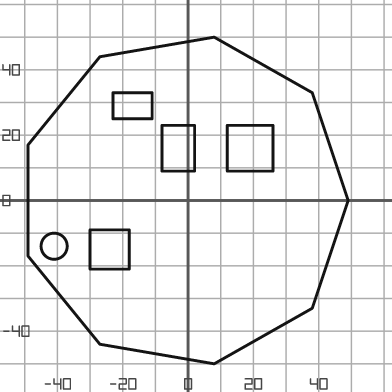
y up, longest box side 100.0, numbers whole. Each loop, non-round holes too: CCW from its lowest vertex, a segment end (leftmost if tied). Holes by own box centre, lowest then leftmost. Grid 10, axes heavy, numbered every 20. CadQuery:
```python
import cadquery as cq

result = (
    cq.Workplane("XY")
    .moveTo(8.0, -50.0)
    .lineTo(38.0, -33.0)
    .lineTo(49.0, 0.0)
    .lineTo(38.0, 33.0)
    .lineTo(8.0, 50.0)
    .lineTo(-27.0, 44.0)
    .lineTo(-49.0, 17.0)
    .lineTo(-49.0, -17.0)
    .lineTo(-27.0, -44.0)
    .close()
    .moveTo(-30.0, -21.0)
    .lineTo(-18.0, -21.0)
    .lineTo(-18.0, -9.0)
    .lineTo(-30.0, -9.0)
    .close()
    .moveTo(-41.0, -14.0)
    .circle(4.0)
    .moveTo(-8.0, 9.0)
    .lineTo(2.0, 9.0)
    .lineTo(2.0, 23.0)
    .lineTo(-8.0, 23.0)
    .close()
    .moveTo(12.0, 9.0)
    .lineTo(26.0, 9.0)
    .lineTo(26.0, 23.0)
    .lineTo(12.0, 23.0)
    .close()
    .moveTo(-23.0, 25.0)
    .lineTo(-11.0, 25.0)
    .lineTo(-11.0, 33.0)
    .lineTo(-23.0, 33.0)
    .close()
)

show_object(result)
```